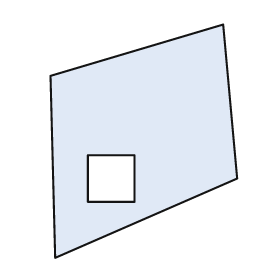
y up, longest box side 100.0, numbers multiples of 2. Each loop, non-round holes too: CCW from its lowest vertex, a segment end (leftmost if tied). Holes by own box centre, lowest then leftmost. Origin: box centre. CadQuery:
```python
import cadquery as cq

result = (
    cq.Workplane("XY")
    .moveTo(-38.0, -50.0)
    .lineTo(40.0, -16.0)
    .lineTo(34.0, 50.0)
    .lineTo(-40.0, 28.0)
    .close()
    .moveTo(-24.0, -26.0)
    .lineTo(-4.0, -26.0)
    .lineTo(-4.0, -6.0)
    .lineTo(-24.0, -6.0)
    .close()
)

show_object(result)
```